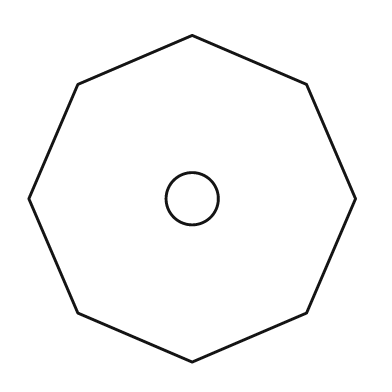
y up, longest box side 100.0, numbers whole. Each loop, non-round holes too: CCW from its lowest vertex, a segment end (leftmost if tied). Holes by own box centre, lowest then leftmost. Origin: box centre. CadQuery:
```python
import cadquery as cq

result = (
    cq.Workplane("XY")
    .moveTo(0.0, -50.0)
    .lineTo(35.0, -35.0)
    .lineTo(50.0, 0.0)
    .lineTo(35.0, 35.0)
    .lineTo(0.0, 50.0)
    .lineTo(-35.0, 35.0)
    .lineTo(-50.0, 0.0)
    .lineTo(-35.0, -35.0)
    .close()
    .moveTo(0.0, 0.0)
    .circle(8.0)
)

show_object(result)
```